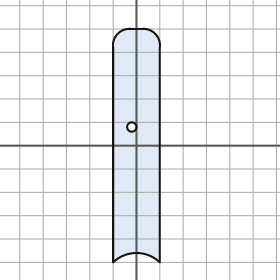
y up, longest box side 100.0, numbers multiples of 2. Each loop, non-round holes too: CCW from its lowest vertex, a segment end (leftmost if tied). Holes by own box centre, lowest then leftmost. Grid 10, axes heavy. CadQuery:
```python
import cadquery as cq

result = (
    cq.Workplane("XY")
    .moveTo(-10.0, -50.0)
    .threePointArc((0.0, -46.0), (10.0, -50.0))
    .lineTo(10.0, 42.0)
    .threePointArc((8.0, 48.0), (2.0, 50.0))
    .lineTo(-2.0, 50.0)
    .threePointArc((-8.0, 48.0), (-10.0, 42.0))
    .close()
    .moveTo(-2.0, 8.0)
    .circle(2.0)
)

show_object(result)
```